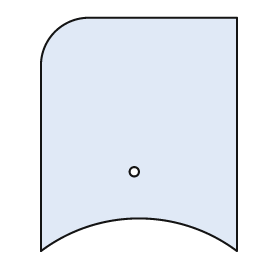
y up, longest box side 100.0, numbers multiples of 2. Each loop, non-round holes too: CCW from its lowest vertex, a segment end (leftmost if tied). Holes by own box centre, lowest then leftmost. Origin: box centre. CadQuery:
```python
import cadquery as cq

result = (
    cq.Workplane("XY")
    .moveTo(-42.0, -50.0)
    .threePointArc((0.0, -36.0), (42.0, -50.0))
    .lineTo(42.0, 50.0)
    .lineTo(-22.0, 50.0)
    .threePointArc((-36.0, 44.0), (-42.0, 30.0))
    .close()
    .moveTo(-2.0, -16.0)
    .circle(2.0)
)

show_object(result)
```